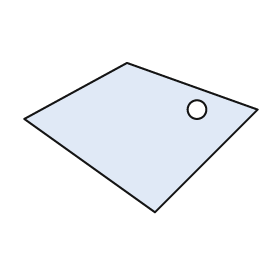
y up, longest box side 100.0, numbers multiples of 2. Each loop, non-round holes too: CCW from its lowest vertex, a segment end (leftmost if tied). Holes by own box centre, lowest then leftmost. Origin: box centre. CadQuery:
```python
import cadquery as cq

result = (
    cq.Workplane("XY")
    .moveTo(6.0, -32.0)
    .lineTo(50.0, 12.0)
    .lineTo(-6.0, 32.0)
    .lineTo(-50.0, 8.0)
    .close()
    .moveTo(24.0, 12.0)
    .circle(4.0)
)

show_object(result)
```